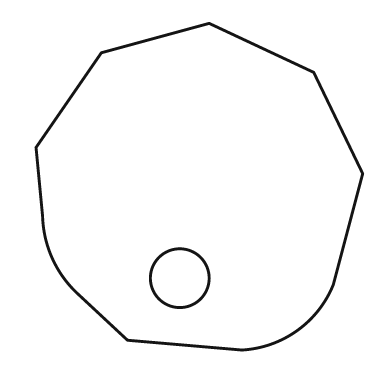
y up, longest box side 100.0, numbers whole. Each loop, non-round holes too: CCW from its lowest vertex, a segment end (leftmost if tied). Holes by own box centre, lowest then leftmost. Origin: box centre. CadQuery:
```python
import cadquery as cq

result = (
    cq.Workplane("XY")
    .moveTo(13.0, -50.0)
    .threePointArc((30.0, -44.0), (41.0, -30.0))
    .lineTo(50.0, 4.0)
    .lineTo(35.0, 35.0)
    .lineTo(3.0, 50.0)
    .lineTo(-30.0, 41.0)
    .lineTo(-50.0, 12.0)
    .lineTo(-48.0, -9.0)
    .threePointArc((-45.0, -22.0), (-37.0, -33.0))
    .lineTo(-22.0, -47.0)
    .close()
    .moveTo(-6.0, -28.0)
    .circle(9.0)
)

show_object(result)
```